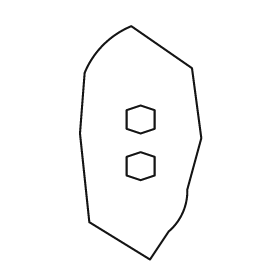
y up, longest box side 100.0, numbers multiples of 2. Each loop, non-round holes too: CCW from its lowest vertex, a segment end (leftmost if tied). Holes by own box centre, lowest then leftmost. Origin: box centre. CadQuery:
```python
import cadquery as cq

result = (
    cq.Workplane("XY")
    .moveTo(4.0, -50.0)
    .lineTo(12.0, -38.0)
    .threePointArc((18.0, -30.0), (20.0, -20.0))
    .lineTo(26.0, 2.0)
    .lineTo(22.0, 32.0)
    .lineTo(-4.0, 50.0)
    .threePointArc((-16.0, 42.0), (-24.0, 30.0))
    .lineTo(-26.0, 4.0)
    .lineTo(-22.0, -34.0)
    .close()
    .moveTo(0.0, -16.0)
    .lineTo(6.0, -14.0)
    .lineTo(6.0, -6.0)
    .lineTo(0.0, -4.0)
    .lineTo(-6.0, -6.0)
    .lineTo(-6.0, -14.0)
    .close()
    .moveTo(0.0, 4.0)
    .lineTo(6.0, 6.0)
    .lineTo(6.0, 14.0)
    .lineTo(0.0, 16.0)
    .lineTo(-6.0, 14.0)
    .lineTo(-6.0, 6.0)
    .close()
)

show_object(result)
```